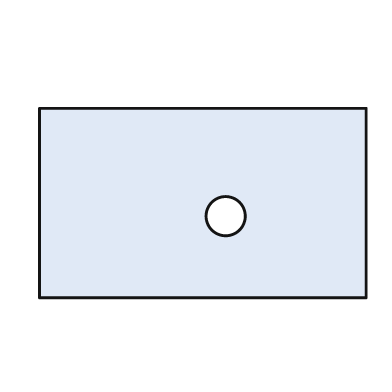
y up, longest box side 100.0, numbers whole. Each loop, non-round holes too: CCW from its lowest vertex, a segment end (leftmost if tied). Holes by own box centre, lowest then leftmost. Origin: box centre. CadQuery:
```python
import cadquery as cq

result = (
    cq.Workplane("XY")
    .moveTo(-50.0, -29.0)
    .lineTo(50.0, -29.0)
    .lineTo(50.0, 29.0)
    .lineTo(-50.0, 29.0)
    .close()
    .moveTo(7.0, -4.0)
    .circle(6.0)
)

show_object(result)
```